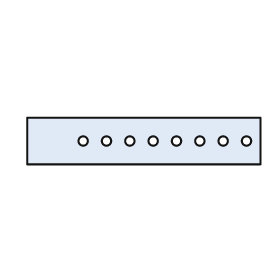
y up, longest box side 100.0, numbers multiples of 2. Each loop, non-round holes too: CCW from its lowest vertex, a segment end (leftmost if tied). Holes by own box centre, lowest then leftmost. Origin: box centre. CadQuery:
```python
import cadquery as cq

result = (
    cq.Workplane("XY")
    .moveTo(-50.0, -10.0)
    .lineTo(50.0, -10.0)
    .lineTo(50.0, 10.0)
    .lineTo(-50.0, 10.0)
    .close()
    .moveTo(-26.0, 0.0)
    .circle(2.0)
    .moveTo(-16.0, 0.0)
    .circle(2.0)
    .moveTo(-6.0, 0.0)
    .circle(2.0)
    .moveTo(4.0, 0.0)
    .circle(2.0)
    .moveTo(14.0, 0.0)
    .circle(2.0)
    .moveTo(24.0, 0.0)
    .circle(2.0)
    .moveTo(34.0, 0.0)
    .circle(2.0)
    .moveTo(44.0, 0.0)
    .circle(2.0)
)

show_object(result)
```